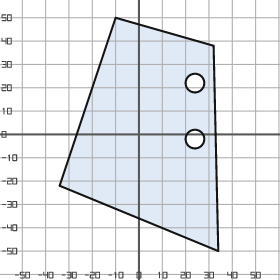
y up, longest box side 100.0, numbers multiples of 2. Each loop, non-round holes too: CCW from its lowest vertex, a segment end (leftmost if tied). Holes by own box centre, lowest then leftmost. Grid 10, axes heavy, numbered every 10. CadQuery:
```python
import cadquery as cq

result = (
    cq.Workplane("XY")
    .moveTo(34.0, -50.0)
    .lineTo(32.0, 38.0)
    .lineTo(-10.0, 50.0)
    .lineTo(-34.0, -22.0)
    .close()
    .moveTo(24.0, -2.0)
    .circle(4.0)
    .moveTo(24.0, 22.0)
    .circle(4.0)
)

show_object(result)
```